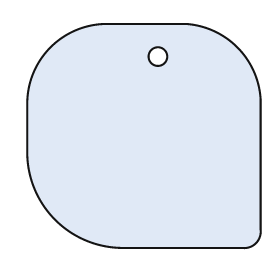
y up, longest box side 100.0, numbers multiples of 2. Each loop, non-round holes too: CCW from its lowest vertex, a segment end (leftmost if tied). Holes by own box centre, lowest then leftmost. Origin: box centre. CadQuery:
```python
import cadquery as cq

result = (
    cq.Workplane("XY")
    .moveTo(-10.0, -48.0)
    .lineTo(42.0, -48.0)
    .threePointArc((48.0, -46.0), (50.0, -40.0))
    .lineTo(50.0, 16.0)
    .threePointArc((40.0, 38.0), (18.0, 48.0))
    .lineTo(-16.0, 48.0)
    .threePointArc((-40.0, 38.0), (-50.0, 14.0))
    .lineTo(-50.0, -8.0)
    .threePointArc((-38.0, -36.0), (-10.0, -48.0))
    .close()
    .moveTo(6.0, 34.0)
    .circle(4.0)
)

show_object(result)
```